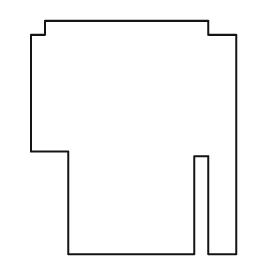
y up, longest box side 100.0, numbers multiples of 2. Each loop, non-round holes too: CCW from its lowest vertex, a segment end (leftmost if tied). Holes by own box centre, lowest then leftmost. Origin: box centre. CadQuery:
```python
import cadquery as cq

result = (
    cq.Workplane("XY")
    .moveTo(-28.0, -50.0)
    .lineTo(26.0, -50.0)
    .lineTo(26.0, -8.0)
    .lineTo(32.0, -8.0)
    .lineTo(32.0, -50.0)
    .lineTo(44.0, -50.0)
    .lineTo(44.0, 44.0)
    .lineTo(32.0, 44.0)
    .lineTo(32.0, 50.0)
    .lineTo(-38.0, 50.0)
    .lineTo(-38.0, 44.0)
    .lineTo(-44.0, 44.0)
    .lineTo(-44.0, -6.0)
    .lineTo(-28.0, -6.0)
    .close()
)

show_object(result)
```